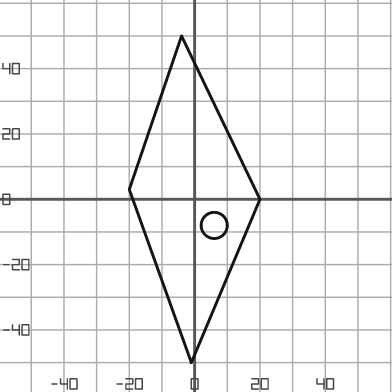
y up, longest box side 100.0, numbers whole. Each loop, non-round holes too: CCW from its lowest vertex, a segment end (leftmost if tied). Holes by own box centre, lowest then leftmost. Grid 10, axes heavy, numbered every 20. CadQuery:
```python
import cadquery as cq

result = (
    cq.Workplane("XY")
    .moveTo(-1.0, -50.0)
    .lineTo(20.0, 0.0)
    .lineTo(-4.0, 50.0)
    .lineTo(-20.0, 3.0)
    .close()
    .moveTo(6.0, -8.0)
    .circle(4.0)
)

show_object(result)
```